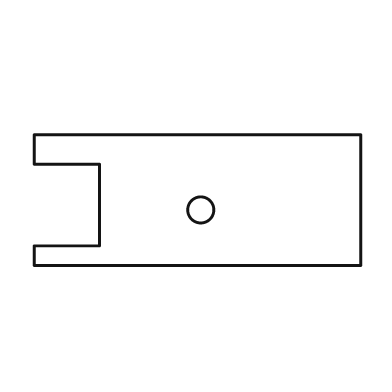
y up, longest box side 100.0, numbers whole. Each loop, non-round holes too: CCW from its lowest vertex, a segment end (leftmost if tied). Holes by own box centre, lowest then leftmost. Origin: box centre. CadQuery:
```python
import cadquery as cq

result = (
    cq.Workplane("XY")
    .moveTo(-50.0, -20.0)
    .lineTo(50.0, -20.0)
    .lineTo(50.0, 20.0)
    .lineTo(-50.0, 20.0)
    .lineTo(-50.0, 11.0)
    .lineTo(-30.0, 11.0)
    .lineTo(-30.0, -14.0)
    .lineTo(-50.0, -14.0)
    .close()
    .moveTo(1.0, -3.0)
    .circle(4.0)
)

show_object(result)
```